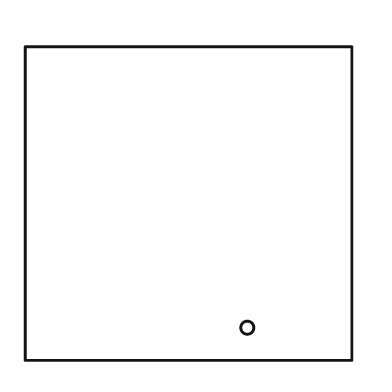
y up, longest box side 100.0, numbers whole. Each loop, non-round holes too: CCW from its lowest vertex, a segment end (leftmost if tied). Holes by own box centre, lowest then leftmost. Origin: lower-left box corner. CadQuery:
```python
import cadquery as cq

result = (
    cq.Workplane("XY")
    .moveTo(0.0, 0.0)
    .lineTo(100.0, 0.0)
    .lineTo(100.0, 96.0)
    .lineTo(0.0, 96.0)
    .close()
    .moveTo(68.0, 10.0)
    .circle(2.0)
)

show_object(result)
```